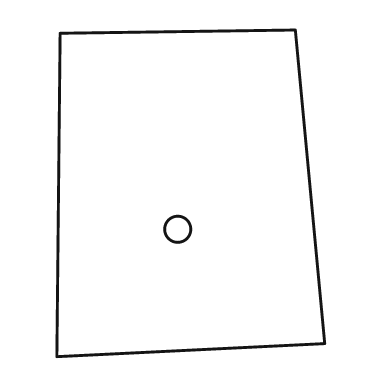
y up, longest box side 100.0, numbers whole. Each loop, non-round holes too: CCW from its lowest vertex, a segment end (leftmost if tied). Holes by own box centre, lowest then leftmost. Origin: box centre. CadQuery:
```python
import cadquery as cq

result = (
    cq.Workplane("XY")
    .moveTo(-41.0, -50.0)
    .lineTo(41.0, -46.0)
    .lineTo(32.0, 50.0)
    .lineTo(-40.0, 49.0)
    .close()
    .moveTo(-4.0, -11.0)
    .circle(4.0)
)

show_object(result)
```